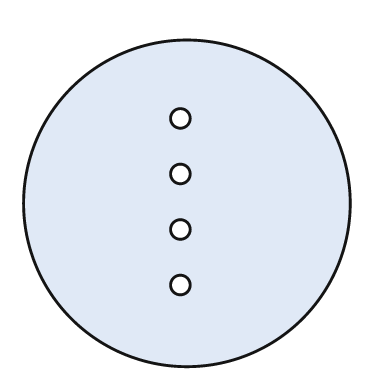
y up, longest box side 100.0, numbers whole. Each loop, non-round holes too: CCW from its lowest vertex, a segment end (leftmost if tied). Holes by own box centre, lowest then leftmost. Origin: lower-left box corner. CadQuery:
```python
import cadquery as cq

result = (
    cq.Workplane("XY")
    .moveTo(50.0, 50.0)
    .circle(50.0)
    .moveTo(48.0, 25.0)
    .circle(3.0)
    .moveTo(48.0, 42.0)
    .circle(3.0)
    .moveTo(48.0, 59.0)
    .circle(3.0)
    .moveTo(48.0, 76.0)
    .circle(3.0)
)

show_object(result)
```